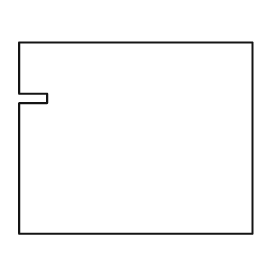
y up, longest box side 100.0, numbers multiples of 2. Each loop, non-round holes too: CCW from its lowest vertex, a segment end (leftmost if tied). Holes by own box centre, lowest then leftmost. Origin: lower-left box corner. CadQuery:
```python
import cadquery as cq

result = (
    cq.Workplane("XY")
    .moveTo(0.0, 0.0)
    .lineTo(100.0, 0.0)
    .lineTo(100.0, 82.0)
    .lineTo(0.0, 82.0)
    .lineTo(0.0, 60.0)
    .lineTo(12.0, 60.0)
    .lineTo(12.0, 56.0)
    .lineTo(0.0, 56.0)
    .close()
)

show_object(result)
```